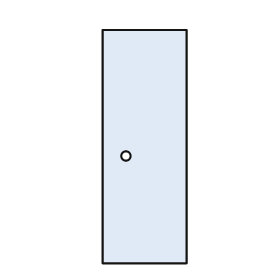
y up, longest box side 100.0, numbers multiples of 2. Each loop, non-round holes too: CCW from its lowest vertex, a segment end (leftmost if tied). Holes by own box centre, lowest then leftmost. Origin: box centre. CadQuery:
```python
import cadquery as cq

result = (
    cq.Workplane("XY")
    .moveTo(-18.0, -50.0)
    .lineTo(18.0, -50.0)
    .lineTo(18.0, 50.0)
    .lineTo(-18.0, 50.0)
    .close()
    .moveTo(-8.0, -4.0)
    .circle(2.0)
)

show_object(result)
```